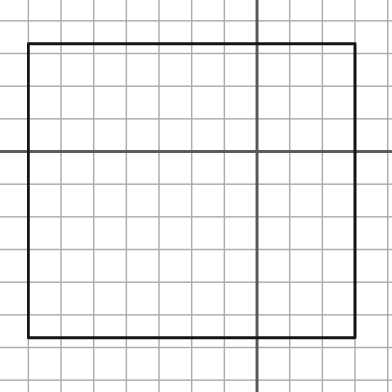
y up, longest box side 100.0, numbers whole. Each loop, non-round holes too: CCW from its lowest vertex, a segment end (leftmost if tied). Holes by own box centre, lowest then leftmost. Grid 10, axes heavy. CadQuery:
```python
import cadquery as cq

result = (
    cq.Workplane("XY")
    .moveTo(-70.0, -57.0)
    .lineTo(30.0, -57.0)
    .lineTo(30.0, 33.0)
    .lineTo(-70.0, 33.0)
    .close()
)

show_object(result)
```